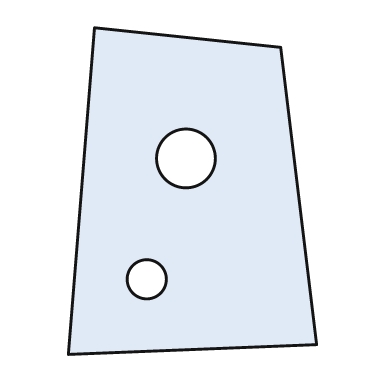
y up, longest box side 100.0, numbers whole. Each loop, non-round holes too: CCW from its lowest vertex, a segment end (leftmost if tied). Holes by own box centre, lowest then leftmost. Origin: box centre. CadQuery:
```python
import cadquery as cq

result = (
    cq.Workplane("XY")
    .moveTo(-38.0, -50.0)
    .lineTo(38.0, -47.0)
    .lineTo(27.0, 44.0)
    .lineTo(-30.0, 50.0)
    .close()
    .moveTo(-14.0, -27.0)
    .circle(6.0)
    .moveTo(-2.0, 10.0)
    .circle(9.0)
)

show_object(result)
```